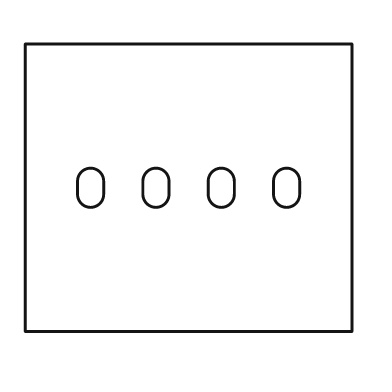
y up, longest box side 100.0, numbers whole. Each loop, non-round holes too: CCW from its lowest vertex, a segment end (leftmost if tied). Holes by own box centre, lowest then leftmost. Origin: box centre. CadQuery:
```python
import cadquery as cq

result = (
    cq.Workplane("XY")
    .moveTo(-50.0, -44.0)
    .lineTo(50.0, -44.0)
    .lineTo(50.0, 44.0)
    .lineTo(-50.0, 44.0)
    .close()
    .moveTo(-34.0, -2.0)
    .threePointArc((-30.0, -6.0), (-26.0, -2.0))
    .lineTo(-26.0, 2.0)
    .threePointArc((-30.0, 6.0), (-34.0, 2.0))
    .close()
    .moveTo(-14.0, -2.0)
    .threePointArc((-10.0, -6.0), (-6.0, -2.0))
    .lineTo(-6.0, 2.0)
    .threePointArc((-10.0, 6.0), (-14.0, 2.0))
    .close()
    .moveTo(6.0, -2.0)
    .threePointArc((10.0, -6.0), (14.0, -2.0))
    .lineTo(14.0, 2.0)
    .threePointArc((10.0, 6.0), (6.0, 2.0))
    .close()
    .moveTo(26.0, -2.0)
    .threePointArc((30.0, -6.0), (34.0, -2.0))
    .lineTo(34.0, 2.0)
    .threePointArc((30.0, 6.0), (26.0, 2.0))
    .close()
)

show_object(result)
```